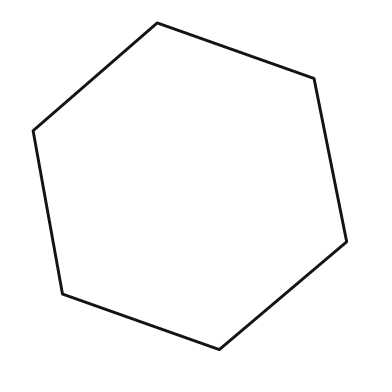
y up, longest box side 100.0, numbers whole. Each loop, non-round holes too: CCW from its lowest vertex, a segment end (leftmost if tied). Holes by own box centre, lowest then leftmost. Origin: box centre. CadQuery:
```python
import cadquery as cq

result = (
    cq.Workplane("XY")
    .moveTo(9.0, -50.0)
    .lineTo(48.0, -17.0)
    .lineTo(38.0, 33.0)
    .lineTo(-10.0, 50.0)
    .lineTo(-48.0, 17.0)
    .lineTo(-39.0, -33.0)
    .close()
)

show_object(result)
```